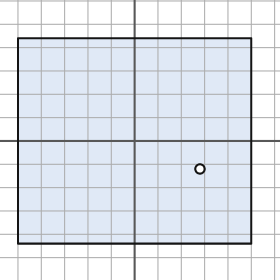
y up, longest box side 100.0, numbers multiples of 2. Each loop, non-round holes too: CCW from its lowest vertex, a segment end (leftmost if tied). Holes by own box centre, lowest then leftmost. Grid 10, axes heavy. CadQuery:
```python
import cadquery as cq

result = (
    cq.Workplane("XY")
    .moveTo(-50.0, -44.0)
    .lineTo(50.0, -44.0)
    .lineTo(50.0, 44.0)
    .lineTo(-50.0, 44.0)
    .close()
    .moveTo(28.0, -12.0)
    .circle(2.0)
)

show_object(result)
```